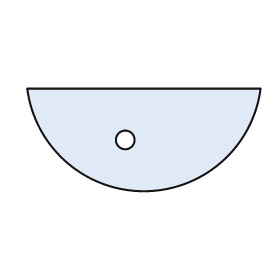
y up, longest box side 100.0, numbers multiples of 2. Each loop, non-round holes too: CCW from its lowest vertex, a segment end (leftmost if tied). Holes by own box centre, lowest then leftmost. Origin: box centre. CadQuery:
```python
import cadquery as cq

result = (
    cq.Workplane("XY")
    .moveTo(-50.0, 22.0)
    .threePointArc((0.0, -22.0), (50.0, 22.0))
    .close()
    .moveTo(-8.0, 0.0)
    .circle(4.0)
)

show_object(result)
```